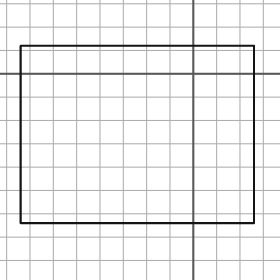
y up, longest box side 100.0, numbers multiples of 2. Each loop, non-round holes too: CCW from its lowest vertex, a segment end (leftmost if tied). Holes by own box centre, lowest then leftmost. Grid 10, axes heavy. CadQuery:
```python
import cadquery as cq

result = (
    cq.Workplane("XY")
    .moveTo(-74.0, -64.0)
    .lineTo(26.0, -64.0)
    .lineTo(26.0, 12.0)
    .lineTo(-74.0, 12.0)
    .close()
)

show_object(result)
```